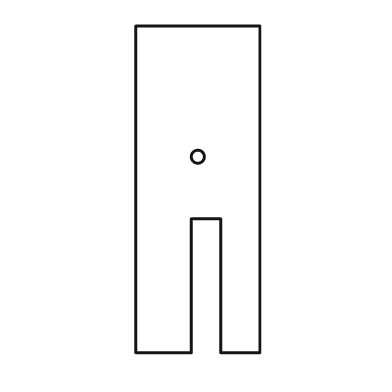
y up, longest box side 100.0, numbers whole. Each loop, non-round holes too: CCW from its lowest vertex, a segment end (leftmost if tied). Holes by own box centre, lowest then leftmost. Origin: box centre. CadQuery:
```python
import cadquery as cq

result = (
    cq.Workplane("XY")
    .moveTo(-19.0, -50.0)
    .lineTo(-2.0, -50.0)
    .lineTo(-2.0, -9.0)
    .lineTo(7.0, -9.0)
    .lineTo(7.0, -50.0)
    .lineTo(19.0, -50.0)
    .lineTo(19.0, 50.0)
    .lineTo(-19.0, 50.0)
    .close()
    .moveTo(0.0, 10.0)
    .circle(2.0)
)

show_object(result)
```